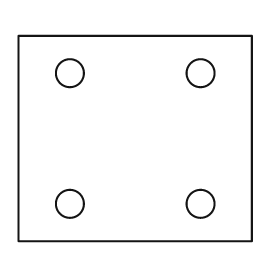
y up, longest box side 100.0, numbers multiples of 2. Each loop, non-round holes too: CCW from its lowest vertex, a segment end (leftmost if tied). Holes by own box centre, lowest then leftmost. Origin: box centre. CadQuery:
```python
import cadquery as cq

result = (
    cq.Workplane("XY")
    .moveTo(-50.0, -44.0)
    .lineTo(50.0, -44.0)
    .lineTo(50.0, 44.0)
    .lineTo(-50.0, 44.0)
    .close()
    .moveTo(-28.0, -28.0)
    .circle(6.0)
    .moveTo(28.0, -28.0)
    .circle(6.0)
    .moveTo(-28.0, 28.0)
    .circle(6.0)
    .moveTo(28.0, 28.0)
    .circle(6.0)
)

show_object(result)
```